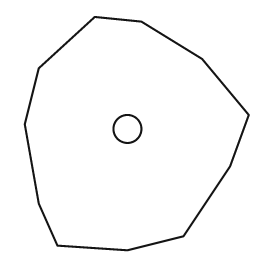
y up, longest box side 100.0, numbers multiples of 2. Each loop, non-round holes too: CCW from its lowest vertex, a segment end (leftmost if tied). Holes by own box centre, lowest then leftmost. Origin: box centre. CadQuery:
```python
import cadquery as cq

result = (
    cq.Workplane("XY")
    .moveTo(-4.0, -50.0)
    .lineTo(20.0, -44.0)
    .lineTo(40.0, -14.0)
    .lineTo(48.0, 8.0)
    .lineTo(28.0, 32.0)
    .lineTo(2.0, 48.0)
    .lineTo(-18.0, 50.0)
    .lineTo(-42.0, 28.0)
    .lineTo(-48.0, 4.0)
    .lineTo(-42.0, -30.0)
    .lineTo(-34.0, -48.0)
    .close()
    .moveTo(-4.0, 2.0)
    .circle(6.0)
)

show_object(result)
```